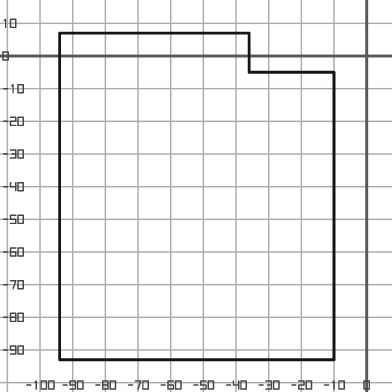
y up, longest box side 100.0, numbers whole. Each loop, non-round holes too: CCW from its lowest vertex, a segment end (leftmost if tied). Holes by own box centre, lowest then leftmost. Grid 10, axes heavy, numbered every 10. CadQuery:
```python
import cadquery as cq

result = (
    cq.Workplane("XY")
    .moveTo(-94.0, -93.0)
    .lineTo(-10.0, -93.0)
    .lineTo(-10.0, -5.0)
    .lineTo(-36.0, -5.0)
    .lineTo(-36.0, 7.0)
    .lineTo(-94.0, 7.0)
    .close()
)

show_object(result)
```